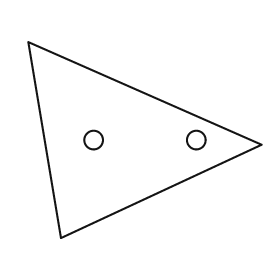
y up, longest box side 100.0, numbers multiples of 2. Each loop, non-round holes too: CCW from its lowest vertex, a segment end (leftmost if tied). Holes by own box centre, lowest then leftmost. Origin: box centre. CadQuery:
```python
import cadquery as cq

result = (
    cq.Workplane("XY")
    .moveTo(-36.0, -42.0)
    .lineTo(50.0, -2.0)
    .lineTo(-50.0, 42.0)
    .close()
    .moveTo(-22.0, 0.0)
    .circle(4.0)
    .moveTo(22.0, 0.0)
    .circle(4.0)
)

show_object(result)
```